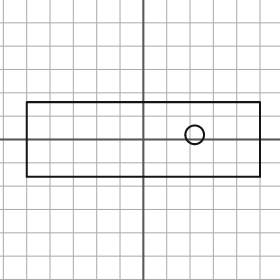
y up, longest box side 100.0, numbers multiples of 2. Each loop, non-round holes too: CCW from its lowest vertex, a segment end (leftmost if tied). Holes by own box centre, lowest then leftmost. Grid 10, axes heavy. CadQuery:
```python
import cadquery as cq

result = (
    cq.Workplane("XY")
    .moveTo(-50.0, -16.0)
    .lineTo(50.0, -16.0)
    .lineTo(50.0, 16.0)
    .lineTo(-50.0, 16.0)
    .close()
    .moveTo(22.0, 2.0)
    .circle(4.0)
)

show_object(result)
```